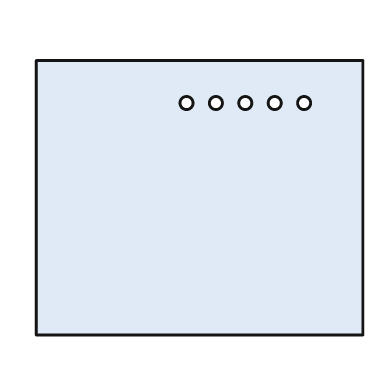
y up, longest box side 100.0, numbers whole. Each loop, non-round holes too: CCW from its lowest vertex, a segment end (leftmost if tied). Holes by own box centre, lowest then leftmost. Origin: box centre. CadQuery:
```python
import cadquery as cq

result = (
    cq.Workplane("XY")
    .moveTo(-50.0, -42.0)
    .lineTo(50.0, -42.0)
    .lineTo(50.0, 42.0)
    .lineTo(-50.0, 42.0)
    .close()
    .moveTo(-4.0, 29.0)
    .circle(2.0)
    .moveTo(5.0, 29.0)
    .circle(2.0)
    .moveTo(14.0, 29.0)
    .circle(2.0)
    .moveTo(23.0, 29.0)
    .circle(2.0)
    .moveTo(32.0, 29.0)
    .circle(2.0)
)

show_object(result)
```